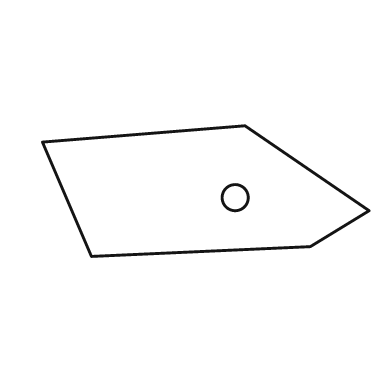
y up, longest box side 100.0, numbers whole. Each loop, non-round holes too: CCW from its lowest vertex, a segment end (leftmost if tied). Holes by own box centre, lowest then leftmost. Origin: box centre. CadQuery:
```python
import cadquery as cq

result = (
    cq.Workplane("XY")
    .moveTo(-35.0, -20.0)
    .lineTo(32.0, -17.0)
    .lineTo(50.0, -6.0)
    .lineTo(12.0, 20.0)
    .lineTo(-50.0, 15.0)
    .close()
    .moveTo(9.0, -2.0)
    .circle(4.0)
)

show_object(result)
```